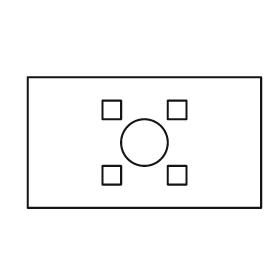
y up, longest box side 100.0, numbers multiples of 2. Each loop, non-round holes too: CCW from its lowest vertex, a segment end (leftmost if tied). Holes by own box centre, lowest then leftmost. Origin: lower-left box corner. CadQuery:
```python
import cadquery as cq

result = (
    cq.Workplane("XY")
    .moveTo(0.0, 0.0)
    .lineTo(100.0, 0.0)
    .lineTo(100.0, 56.0)
    .lineTo(0.0, 56.0)
    .close()
    .moveTo(32.0, 10.0)
    .lineTo(40.0, 10.0)
    .lineTo(40.0, 18.0)
    .lineTo(32.0, 18.0)
    .close()
    .moveTo(60.0, 10.0)
    .lineTo(68.0, 10.0)
    .lineTo(68.0, 18.0)
    .lineTo(60.0, 18.0)
    .close()
    .moveTo(50.0, 28.0)
    .circle(10.0)
    .moveTo(32.0, 38.0)
    .lineTo(40.0, 38.0)
    .lineTo(40.0, 46.0)
    .lineTo(32.0, 46.0)
    .close()
    .moveTo(60.0, 38.0)
    .lineTo(68.0, 38.0)
    .lineTo(68.0, 46.0)
    .lineTo(60.0, 46.0)
    .close()
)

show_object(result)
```